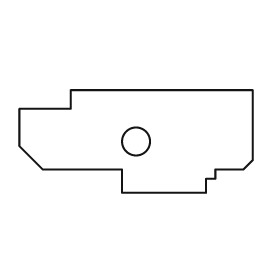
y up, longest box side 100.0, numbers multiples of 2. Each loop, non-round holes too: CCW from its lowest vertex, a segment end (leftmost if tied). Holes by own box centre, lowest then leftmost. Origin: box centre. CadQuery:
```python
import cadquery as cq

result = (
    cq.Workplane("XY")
    .moveTo(-6.0, -22.0)
    .lineTo(30.0, -22.0)
    .lineTo(30.0, -16.0)
    .lineTo(34.0, -16.0)
    .lineTo(34.0, -12.0)
    .lineTo(46.0, -12.0)
    .lineTo(50.0, -8.0)
    .lineTo(50.0, 22.0)
    .lineTo(-28.0, 22.0)
    .lineTo(-28.0, 14.0)
    .lineTo(-50.0, 14.0)
    .lineTo(-50.0, -2.0)
    .lineTo(-40.0, -12.0)
    .lineTo(-6.0, -12.0)
    .close()
    .moveTo(0.0, 0.0)
    .circle(6.0)
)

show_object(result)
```